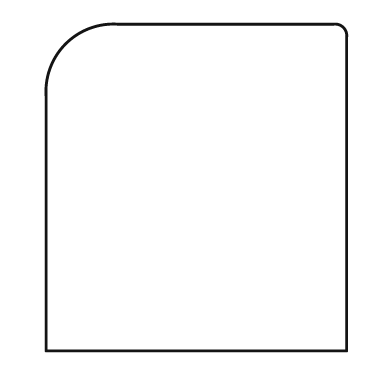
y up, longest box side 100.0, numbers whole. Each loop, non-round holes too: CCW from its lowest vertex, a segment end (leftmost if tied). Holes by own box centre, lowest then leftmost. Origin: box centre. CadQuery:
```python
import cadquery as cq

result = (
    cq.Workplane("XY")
    .moveTo(-46.0, -50.0)
    .lineTo(46.0, -50.0)
    .lineTo(46.0, 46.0)
    .threePointArc((45.0, 49.0), (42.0, 50.0))
    .lineTo(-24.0, 50.0)
    .threePointArc((-40.0, 44.0), (-46.0, 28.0))
    .close()
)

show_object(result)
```